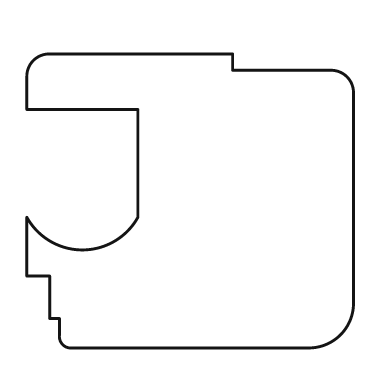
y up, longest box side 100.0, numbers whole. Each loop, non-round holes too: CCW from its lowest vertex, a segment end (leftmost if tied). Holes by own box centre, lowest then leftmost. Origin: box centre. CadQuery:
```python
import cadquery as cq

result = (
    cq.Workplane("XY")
    .moveTo(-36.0, -45.0)
    .lineTo(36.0, -45.0)
    .threePointArc((46.0, -41.0), (50.0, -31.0))
    .lineTo(50.0, 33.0)
    .threePointArc((48.0, 38.0), (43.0, 40.0))
    .lineTo(13.0, 40.0)
    .lineTo(13.0, 45.0)
    .lineTo(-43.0, 45.0)
    .threePointArc((-48.0, 43.0), (-50.0, 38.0))
    .lineTo(-50.0, 28.0)
    .lineTo(-16.0, 28.0)
    .lineTo(-16.0, -5.0)
    .threePointArc((-33.0, -15.0), (-50.0, -5.0))
    .lineTo(-50.0, -23.0)
    .lineTo(-43.0, -23.0)
    .lineTo(-43.0, -36.0)
    .lineTo(-40.0, -36.0)
    .lineTo(-40.0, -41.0)
    .threePointArc((-39.0, -44.0), (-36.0, -45.0))
    .close()
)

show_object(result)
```